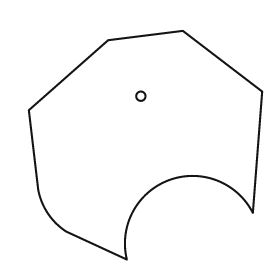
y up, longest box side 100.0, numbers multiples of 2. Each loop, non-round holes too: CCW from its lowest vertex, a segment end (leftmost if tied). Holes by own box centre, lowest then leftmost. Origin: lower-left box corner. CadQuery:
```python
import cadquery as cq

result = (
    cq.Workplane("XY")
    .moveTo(42.0, 0.0)
    .threePointArc((60.0, 34.0), (96.0, 20.0))
    .lineTo(100.0, 72.0)
    .lineTo(66.0, 98.0)
    .lineTo(34.0, 94.0)
    .lineTo(0.0, 64.0)
    .lineTo(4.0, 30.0)
    .threePointArc((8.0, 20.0), (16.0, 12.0))
    .close()
    .moveTo(48.0, 70.0)
    .circle(2.0)
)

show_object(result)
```